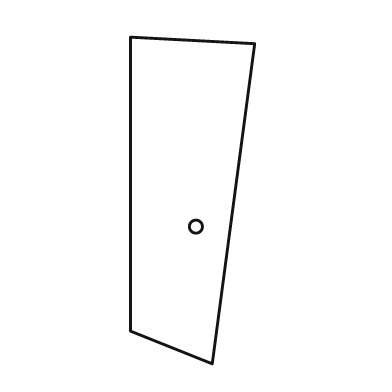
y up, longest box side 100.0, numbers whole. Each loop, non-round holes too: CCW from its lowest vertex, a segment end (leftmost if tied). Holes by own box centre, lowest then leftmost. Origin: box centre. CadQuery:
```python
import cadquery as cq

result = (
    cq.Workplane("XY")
    .moveTo(6.0, -50.0)
    .lineTo(19.0, 48.0)
    .lineTo(-19.0, 50.0)
    .lineTo(-19.0, -40.0)
    .close()
    .moveTo(1.0, -8.0)
    .circle(2.0)
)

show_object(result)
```